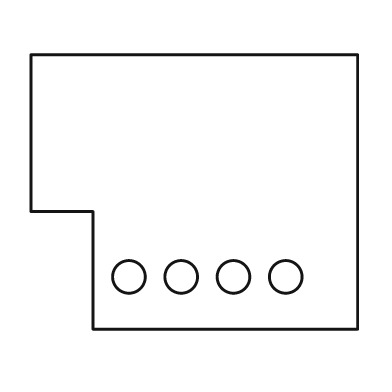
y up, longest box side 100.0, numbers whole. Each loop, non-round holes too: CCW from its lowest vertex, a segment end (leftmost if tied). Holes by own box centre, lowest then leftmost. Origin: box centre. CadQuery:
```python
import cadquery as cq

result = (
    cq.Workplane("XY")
    .moveTo(-31.0, -42.0)
    .lineTo(50.0, -42.0)
    .lineTo(50.0, 42.0)
    .lineTo(-50.0, 42.0)
    .lineTo(-50.0, -6.0)
    .lineTo(-31.0, -6.0)
    .close()
    .moveTo(-20.0, -26.0)
    .circle(5.0)
    .moveTo(-4.0, -26.0)
    .circle(5.0)
    .moveTo(12.0, -26.0)
    .circle(5.0)
    .moveTo(28.0, -26.0)
    .circle(5.0)
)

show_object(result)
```